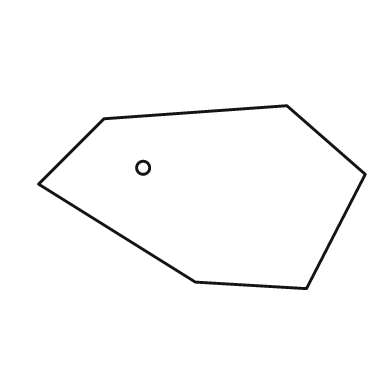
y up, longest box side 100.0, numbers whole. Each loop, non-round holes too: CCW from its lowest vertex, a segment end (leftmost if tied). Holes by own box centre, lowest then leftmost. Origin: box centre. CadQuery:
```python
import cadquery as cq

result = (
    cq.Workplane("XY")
    .moveTo(32.0, -28.0)
    .lineTo(50.0, 7.0)
    .lineTo(26.0, 28.0)
    .lineTo(-30.0, 24.0)
    .lineTo(-50.0, 4.0)
    .lineTo(-2.0, -26.0)
    .close()
    .moveTo(-18.0, 9.0)
    .circle(2.0)
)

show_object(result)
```